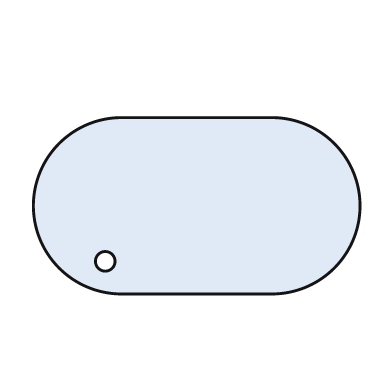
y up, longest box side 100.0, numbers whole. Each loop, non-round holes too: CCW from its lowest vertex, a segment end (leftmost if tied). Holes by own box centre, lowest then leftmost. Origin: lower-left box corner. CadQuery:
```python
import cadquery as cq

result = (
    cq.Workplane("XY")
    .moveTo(27.0, 0.0)
    .lineTo(73.0, 0.0)
    .threePointArc((100.0, 27.0), (73.0, 54.0))
    .lineTo(27.0, 54.0)
    .threePointArc((0.0, 27.0), (27.0, 0.0))
    .close()
    .moveTo(22.0, 10.0)
    .circle(3.0)
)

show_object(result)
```